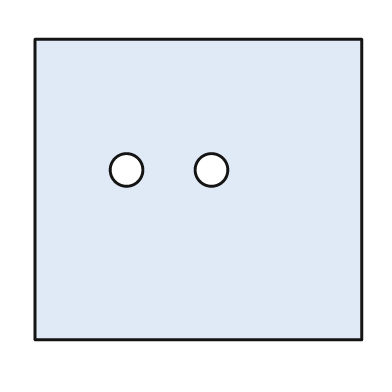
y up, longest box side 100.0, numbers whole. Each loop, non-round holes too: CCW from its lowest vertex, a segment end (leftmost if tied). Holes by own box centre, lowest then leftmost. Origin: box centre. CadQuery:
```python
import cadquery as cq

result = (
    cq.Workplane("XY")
    .moveTo(-50.0, -46.0)
    .lineTo(50.0, -46.0)
    .lineTo(50.0, 46.0)
    .lineTo(-50.0, 46.0)
    .close()
    .moveTo(-22.0, 6.0)
    .circle(5.0)
    .moveTo(4.0, 6.0)
    .circle(5.0)
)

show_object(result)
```